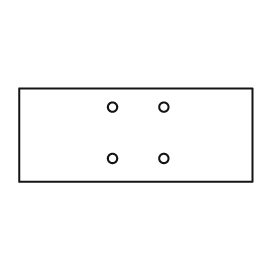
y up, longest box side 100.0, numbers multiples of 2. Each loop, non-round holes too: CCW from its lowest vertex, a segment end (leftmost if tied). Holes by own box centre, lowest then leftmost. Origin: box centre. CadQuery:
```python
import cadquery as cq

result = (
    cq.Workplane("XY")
    .moveTo(-50.0, -20.0)
    .lineTo(50.0, -20.0)
    .lineTo(50.0, 20.0)
    .lineTo(-50.0, 20.0)
    .close()
    .moveTo(-10.0, -10.0)
    .circle(2.0)
    .moveTo(12.0, -10.0)
    .circle(2.0)
    .moveTo(-10.0, 12.0)
    .circle(2.0)
    .moveTo(12.0, 12.0)
    .circle(2.0)
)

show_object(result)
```